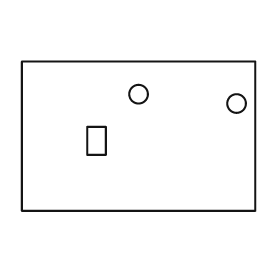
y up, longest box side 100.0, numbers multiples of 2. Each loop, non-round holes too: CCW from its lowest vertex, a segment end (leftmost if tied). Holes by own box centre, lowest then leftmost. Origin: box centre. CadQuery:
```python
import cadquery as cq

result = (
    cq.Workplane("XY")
    .moveTo(-50.0, -32.0)
    .lineTo(50.0, -32.0)
    .lineTo(50.0, 32.0)
    .lineTo(-50.0, 32.0)
    .close()
    .moveTo(-22.0, -8.0)
    .lineTo(-14.0, -8.0)
    .lineTo(-14.0, 4.0)
    .lineTo(-22.0, 4.0)
    .close()
    .moveTo(42.0, 14.0)
    .circle(4.0)
    .moveTo(0.0, 18.0)
    .circle(4.0)
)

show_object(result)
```